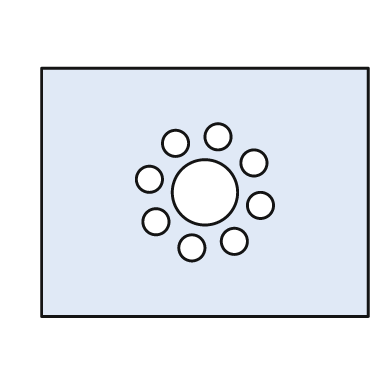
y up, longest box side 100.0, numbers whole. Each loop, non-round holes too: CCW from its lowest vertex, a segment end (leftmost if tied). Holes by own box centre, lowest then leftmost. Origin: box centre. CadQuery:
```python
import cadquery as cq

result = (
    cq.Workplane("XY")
    .moveTo(-50.0, -38.0)
    .lineTo(50.0, -38.0)
    .lineTo(50.0, 38.0)
    .lineTo(-50.0, 38.0)
    .close()
    .moveTo(-4.0, -17.0)
    .circle(4.0)
    .moveTo(9.0, -15.0)
    .circle(4.0)
    .moveTo(-15.0, -9.0)
    .circle(4.0)
    .moveTo(17.0, -4.0)
    .circle(4.0)
    .moveTo(0.0, 0.0)
    .circle(10.0)
    .moveTo(-17.0, 4.0)
    .circle(4.0)
    .moveTo(15.0, 9.0)
    .circle(4.0)
    .moveTo(-9.0, 15.0)
    .circle(4.0)
    .moveTo(4.0, 17.0)
    .circle(4.0)
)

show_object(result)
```